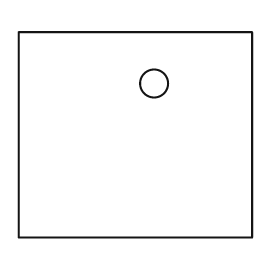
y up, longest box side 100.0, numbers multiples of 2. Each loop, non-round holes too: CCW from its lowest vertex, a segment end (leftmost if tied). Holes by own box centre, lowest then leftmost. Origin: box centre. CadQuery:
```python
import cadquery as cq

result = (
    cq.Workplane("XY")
    .moveTo(-50.0, -44.0)
    .lineTo(50.0, -44.0)
    .lineTo(50.0, 44.0)
    .lineTo(-50.0, 44.0)
    .close()
    .moveTo(8.0, 22.0)
    .circle(6.0)
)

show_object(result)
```